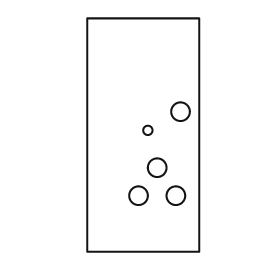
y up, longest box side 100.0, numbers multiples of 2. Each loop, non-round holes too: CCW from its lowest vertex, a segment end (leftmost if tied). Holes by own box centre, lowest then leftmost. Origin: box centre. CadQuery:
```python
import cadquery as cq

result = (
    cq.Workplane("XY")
    .moveTo(-24.0, -50.0)
    .lineTo(24.0, -50.0)
    .lineTo(24.0, 50.0)
    .lineTo(-24.0, 50.0)
    .close()
    .moveTo(-2.0, -26.0)
    .circle(4.0)
    .moveTo(14.0, -26.0)
    .circle(4.0)
    .moveTo(6.0, -14.0)
    .circle(4.0)
    .moveTo(2.0, 2.0)
    .circle(2.0)
    .moveTo(16.0, 10.0)
    .circle(4.0)
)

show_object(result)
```